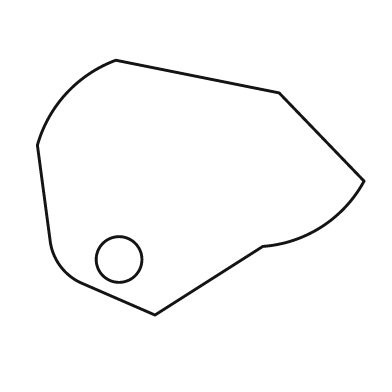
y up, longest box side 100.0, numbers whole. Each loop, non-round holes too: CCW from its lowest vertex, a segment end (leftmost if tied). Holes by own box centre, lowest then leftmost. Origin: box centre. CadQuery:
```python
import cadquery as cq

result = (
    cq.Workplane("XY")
    .moveTo(-14.0, -39.0)
    .lineTo(19.0, -18.0)
    .threePointArc((37.0, -12.0), (50.0, 2.0))
    .lineTo(24.0, 29.0)
    .lineTo(-26.0, 39.0)
    .threePointArc((-41.0, 29.0), (-50.0, 13.0))
    .lineTo(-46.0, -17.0)
    .threePointArc((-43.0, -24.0), (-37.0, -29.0))
    .close()
    .moveTo(-25.0, -22.0)
    .circle(7.0)
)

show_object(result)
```